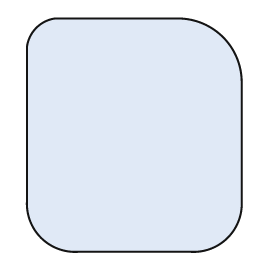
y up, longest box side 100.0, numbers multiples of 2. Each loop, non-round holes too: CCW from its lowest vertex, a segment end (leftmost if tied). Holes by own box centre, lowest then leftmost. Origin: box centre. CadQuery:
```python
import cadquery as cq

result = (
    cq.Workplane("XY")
    .moveTo(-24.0, -50.0)
    .lineTo(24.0, -50.0)
    .threePointArc((40.0, -44.0), (46.0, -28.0))
    .lineTo(46.0, 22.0)
    .threePointArc((38.0, 42.0), (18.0, 50.0))
    .lineTo(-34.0, 50.0)
    .threePointArc((-42.0, 46.0), (-46.0, 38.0))
    .lineTo(-46.0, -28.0)
    .threePointArc((-40.0, -44.0), (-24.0, -50.0))
    .close()
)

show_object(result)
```